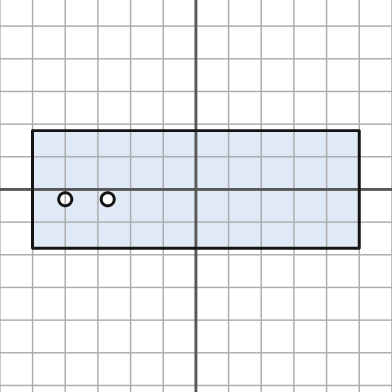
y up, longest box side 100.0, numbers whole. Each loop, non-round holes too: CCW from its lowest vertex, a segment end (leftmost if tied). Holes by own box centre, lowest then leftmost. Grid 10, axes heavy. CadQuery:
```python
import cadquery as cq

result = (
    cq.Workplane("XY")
    .moveTo(-50.0, -18.0)
    .lineTo(50.0, -18.0)
    .lineTo(50.0, 18.0)
    .lineTo(-50.0, 18.0)
    .close()
    .moveTo(-40.0, -3.0)
    .circle(2.0)
    .moveTo(-27.0, -3.0)
    .circle(2.0)
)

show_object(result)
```